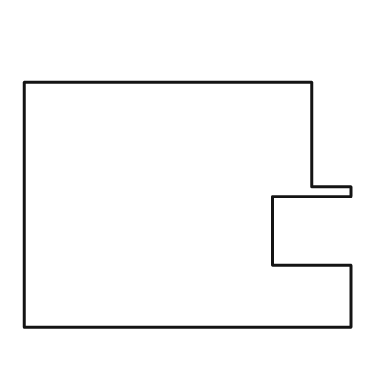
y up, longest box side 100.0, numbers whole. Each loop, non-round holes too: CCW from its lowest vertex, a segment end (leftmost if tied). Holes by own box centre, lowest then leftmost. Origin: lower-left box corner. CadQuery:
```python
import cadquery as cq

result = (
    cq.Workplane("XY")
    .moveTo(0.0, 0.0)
    .lineTo(100.0, 0.0)
    .lineTo(100.0, 19.0)
    .lineTo(76.0, 19.0)
    .lineTo(76.0, 40.0)
    .lineTo(100.0, 40.0)
    .lineTo(100.0, 43.0)
    .lineTo(88.0, 43.0)
    .lineTo(88.0, 75.0)
    .lineTo(0.0, 75.0)
    .close()
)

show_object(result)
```